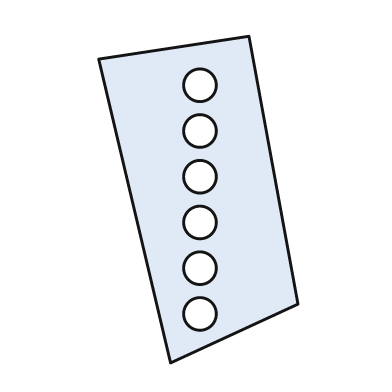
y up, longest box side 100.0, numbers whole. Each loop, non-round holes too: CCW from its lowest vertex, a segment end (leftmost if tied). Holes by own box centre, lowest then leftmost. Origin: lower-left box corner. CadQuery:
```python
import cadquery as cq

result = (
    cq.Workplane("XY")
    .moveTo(22.0, 0.0)
    .lineTo(61.0, 18.0)
    .lineTo(46.0, 100.0)
    .lineTo(0.0, 93.0)
    .close()
    .moveTo(31.0, 15.0)
    .circle(5.0)
    .moveTo(31.0, 29.0)
    .circle(5.0)
    .moveTo(31.0, 43.0)
    .circle(5.0)
    .moveTo(31.0, 57.0)
    .circle(5.0)
    .moveTo(31.0, 71.0)
    .circle(5.0)
    .moveTo(31.0, 85.0)
    .circle(5.0)
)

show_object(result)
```